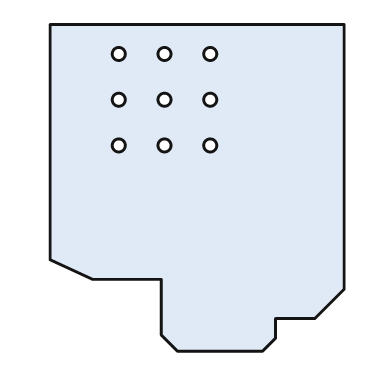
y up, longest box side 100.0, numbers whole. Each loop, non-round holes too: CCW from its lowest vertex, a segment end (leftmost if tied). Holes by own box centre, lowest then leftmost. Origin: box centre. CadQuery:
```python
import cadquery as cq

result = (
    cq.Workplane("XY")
    .moveTo(-6.0, -50.0)
    .lineTo(20.0, -50.0)
    .lineTo(24.0, -46.0)
    .lineTo(24.0, -40.0)
    .lineTo(36.0, -40.0)
    .lineTo(45.0, -31.0)
    .lineTo(45.0, 50.0)
    .lineTo(-45.0, 50.0)
    .lineTo(-45.0, -22.0)
    .lineTo(-32.0, -28.0)
    .lineTo(-11.0, -28.0)
    .lineTo(-11.0, -45.0)
    .close()
    .moveTo(-24.0, 13.0)
    .circle(2.0)
    .moveTo(-10.0, 13.0)
    .circle(2.0)
    .moveTo(4.0, 13.0)
    .circle(2.0)
    .moveTo(-24.0, 27.0)
    .circle(2.0)
    .moveTo(-10.0, 27.0)
    .circle(2.0)
    .moveTo(4.0, 27.0)
    .circle(2.0)
    .moveTo(-24.0, 41.0)
    .circle(2.0)
    .moveTo(-10.0, 41.0)
    .circle(2.0)
    .moveTo(4.0, 41.0)
    .circle(2.0)
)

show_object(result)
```